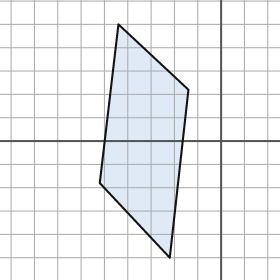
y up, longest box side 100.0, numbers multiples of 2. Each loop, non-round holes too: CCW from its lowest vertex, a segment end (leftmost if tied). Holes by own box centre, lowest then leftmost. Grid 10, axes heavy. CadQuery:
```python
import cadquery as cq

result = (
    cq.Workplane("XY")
    .moveTo(-22.0, -50.0)
    .lineTo(-14.0, 22.0)
    .lineTo(-44.0, 50.0)
    .lineTo(-52.0, -18.0)
    .close()
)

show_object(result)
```